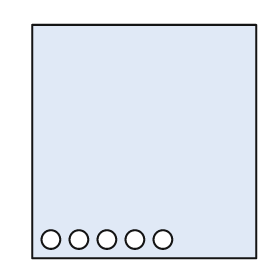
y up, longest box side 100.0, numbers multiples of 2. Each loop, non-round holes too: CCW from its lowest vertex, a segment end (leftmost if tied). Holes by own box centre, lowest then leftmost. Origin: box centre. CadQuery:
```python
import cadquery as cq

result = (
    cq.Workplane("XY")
    .moveTo(-48.0, -50.0)
    .lineTo(48.0, -50.0)
    .lineTo(48.0, 50.0)
    .lineTo(-48.0, 50.0)
    .close()
    .moveTo(-40.0, -42.0)
    .circle(4.0)
    .moveTo(-28.0, -42.0)
    .circle(4.0)
    .moveTo(-16.0, -42.0)
    .circle(4.0)
    .moveTo(-4.0, -42.0)
    .circle(4.0)
    .moveTo(8.0, -42.0)
    .circle(4.0)
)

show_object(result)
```